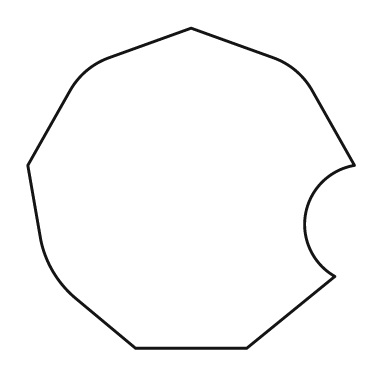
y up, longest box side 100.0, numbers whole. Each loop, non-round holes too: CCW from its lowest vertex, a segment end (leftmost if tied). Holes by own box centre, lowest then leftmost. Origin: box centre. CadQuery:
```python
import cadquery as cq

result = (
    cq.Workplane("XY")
    .moveTo(-17.0, -49.0)
    .lineTo(17.0, -49.0)
    .lineTo(44.0, -27.0)
    .threePointArc((35.0, -8.0), (50.0, 7.0))
    .lineTo(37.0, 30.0)
    .threePointArc((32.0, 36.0), (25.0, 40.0))
    .lineTo(0.0, 49.0)
    .lineTo(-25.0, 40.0)
    .threePointArc((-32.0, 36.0), (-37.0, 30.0))
    .lineTo(-50.0, 7.0)
    .lineTo(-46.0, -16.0)
    .threePointArc((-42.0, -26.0), (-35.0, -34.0))
    .close()
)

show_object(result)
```